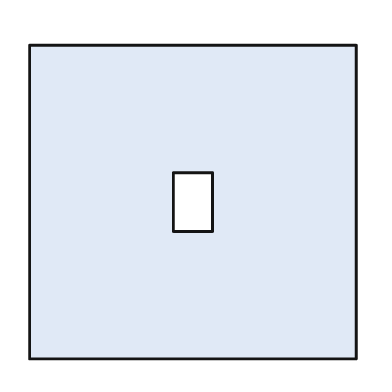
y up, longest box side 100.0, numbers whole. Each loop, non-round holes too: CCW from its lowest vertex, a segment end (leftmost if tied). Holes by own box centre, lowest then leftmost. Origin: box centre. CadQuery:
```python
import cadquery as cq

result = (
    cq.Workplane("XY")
    .moveTo(-50.0, -48.0)
    .lineTo(50.0, -48.0)
    .lineTo(50.0, 48.0)
    .lineTo(-50.0, 48.0)
    .close()
    .moveTo(-6.0, -9.0)
    .lineTo(6.0, -9.0)
    .lineTo(6.0, 9.0)
    .lineTo(-6.0, 9.0)
    .close()
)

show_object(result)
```